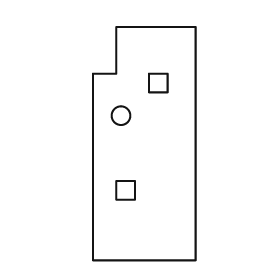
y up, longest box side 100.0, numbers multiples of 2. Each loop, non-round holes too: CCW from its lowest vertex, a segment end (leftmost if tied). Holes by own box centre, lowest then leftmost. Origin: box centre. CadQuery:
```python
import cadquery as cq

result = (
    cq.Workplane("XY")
    .moveTo(-22.0, -50.0)
    .lineTo(22.0, -50.0)
    .lineTo(22.0, 50.0)
    .lineTo(-12.0, 50.0)
    .lineTo(-12.0, 30.0)
    .lineTo(-22.0, 30.0)
    .close()
    .moveTo(-12.0, -24.0)
    .lineTo(-4.0, -24.0)
    .lineTo(-4.0, -16.0)
    .lineTo(-12.0, -16.0)
    .close()
    .moveTo(-10.0, 12.0)
    .circle(4.0)
    .moveTo(2.0, 22.0)
    .lineTo(10.0, 22.0)
    .lineTo(10.0, 30.0)
    .lineTo(2.0, 30.0)
    .close()
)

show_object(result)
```